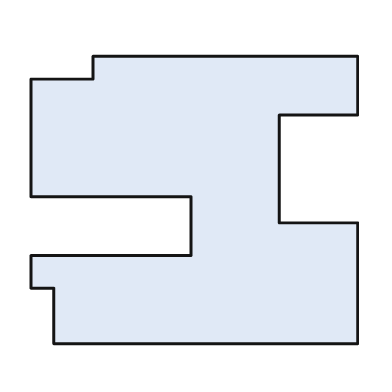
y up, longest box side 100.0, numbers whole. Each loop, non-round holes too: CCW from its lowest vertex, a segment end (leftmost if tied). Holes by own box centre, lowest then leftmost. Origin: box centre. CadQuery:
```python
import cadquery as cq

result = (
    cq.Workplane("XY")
    .moveTo(-43.0, -44.0)
    .lineTo(50.0, -44.0)
    .lineTo(50.0, -7.0)
    .lineTo(26.0, -7.0)
    .lineTo(26.0, 26.0)
    .lineTo(50.0, 26.0)
    .lineTo(50.0, 44.0)
    .lineTo(-31.0, 44.0)
    .lineTo(-31.0, 37.0)
    .lineTo(-50.0, 37.0)
    .lineTo(-50.0, 1.0)
    .lineTo(-1.0, 1.0)
    .lineTo(-1.0, -17.0)
    .lineTo(-50.0, -17.0)
    .lineTo(-50.0, -27.0)
    .lineTo(-43.0, -27.0)
    .close()
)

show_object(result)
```